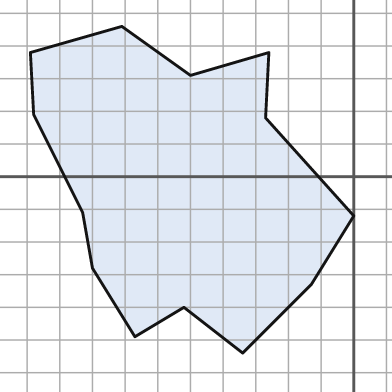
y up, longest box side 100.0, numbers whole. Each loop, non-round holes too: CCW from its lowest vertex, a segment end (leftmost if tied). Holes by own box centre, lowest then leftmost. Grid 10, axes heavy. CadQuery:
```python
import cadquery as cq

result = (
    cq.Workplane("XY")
    .moveTo(-34.0, -54.0)
    .lineTo(-13.0, -33.0)
    .lineTo(0.0, -12.0)
    .lineTo(-27.0, 18.0)
    .lineTo(-26.0, 38.0)
    .lineTo(-50.0, 31.0)
    .lineTo(-71.0, 46.0)
    .lineTo(-99.0, 38.0)
    .lineTo(-98.0, 19.0)
    .lineTo(-83.0, -11.0)
    .lineTo(-80.0, -28.0)
    .lineTo(-67.0, -49.0)
    .lineTo(-52.0, -40.0)
    .close()
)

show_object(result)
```